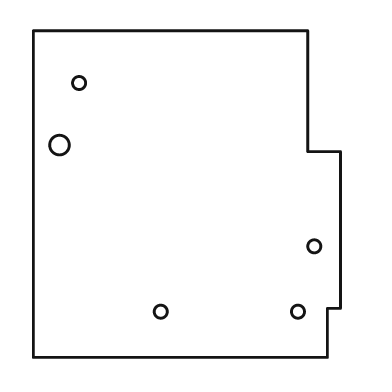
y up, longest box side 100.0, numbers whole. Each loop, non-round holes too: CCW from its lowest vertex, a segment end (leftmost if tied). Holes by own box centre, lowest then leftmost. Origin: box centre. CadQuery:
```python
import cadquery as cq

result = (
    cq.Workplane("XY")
    .moveTo(-47.0, -50.0)
    .lineTo(43.0, -50.0)
    .lineTo(43.0, -35.0)
    .lineTo(47.0, -35.0)
    .lineTo(47.0, 13.0)
    .lineTo(37.0, 13.0)
    .lineTo(37.0, 50.0)
    .lineTo(-47.0, 50.0)
    .close()
    .moveTo(-8.0, -36.0)
    .circle(2.0)
    .moveTo(34.0, -36.0)
    .circle(2.0)
    .moveTo(39.0, -16.0)
    .circle(2.0)
    .moveTo(-39.0, 15.0)
    .circle(3.0)
    .moveTo(-33.0, 34.0)
    .circle(2.0)
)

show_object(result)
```